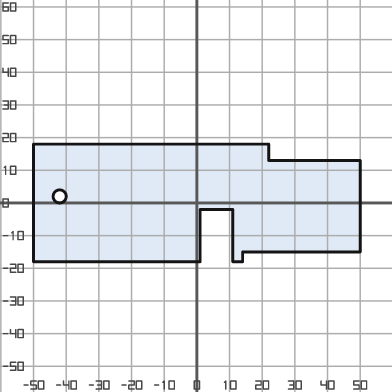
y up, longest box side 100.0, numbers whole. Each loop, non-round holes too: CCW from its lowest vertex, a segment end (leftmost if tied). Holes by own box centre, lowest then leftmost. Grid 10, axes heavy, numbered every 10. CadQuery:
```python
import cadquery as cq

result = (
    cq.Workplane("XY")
    .moveTo(-50.0, -18.0)
    .lineTo(1.0, -18.0)
    .lineTo(1.0, -2.0)
    .lineTo(11.0, -2.0)
    .lineTo(11.0, -18.0)
    .lineTo(14.0, -18.0)
    .lineTo(14.0, -15.0)
    .lineTo(50.0, -15.0)
    .lineTo(50.0, 13.0)
    .lineTo(22.0, 13.0)
    .lineTo(22.0, 18.0)
    .lineTo(-50.0, 18.0)
    .close()
    .moveTo(-42.0, 2.0)
    .circle(2.0)
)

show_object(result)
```